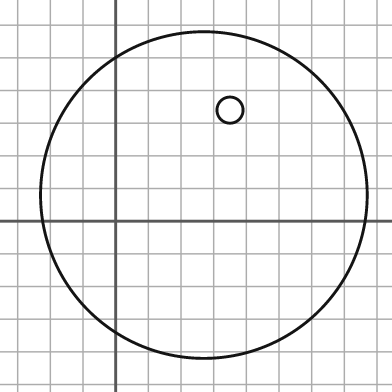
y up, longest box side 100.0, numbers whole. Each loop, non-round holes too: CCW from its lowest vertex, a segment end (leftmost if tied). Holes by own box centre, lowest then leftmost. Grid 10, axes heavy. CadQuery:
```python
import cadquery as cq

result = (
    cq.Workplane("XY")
    .moveTo(27.0, 8.0)
    .circle(50.0)
    .moveTo(35.0, 34.0)
    .circle(4.0)
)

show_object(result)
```